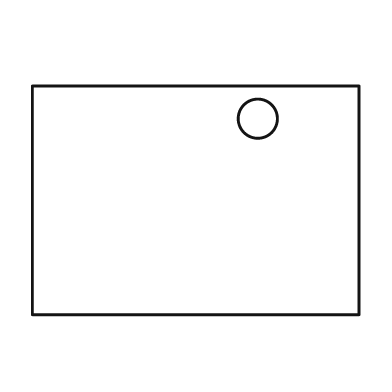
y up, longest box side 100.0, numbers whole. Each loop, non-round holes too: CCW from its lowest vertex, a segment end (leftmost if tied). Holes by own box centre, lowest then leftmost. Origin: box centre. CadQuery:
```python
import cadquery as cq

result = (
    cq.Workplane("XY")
    .moveTo(-50.0, -35.0)
    .lineTo(50.0, -35.0)
    .lineTo(50.0, 35.0)
    .lineTo(-50.0, 35.0)
    .close()
    .moveTo(19.0, 25.0)
    .circle(6.0)
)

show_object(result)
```